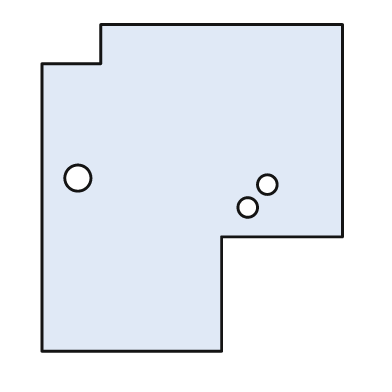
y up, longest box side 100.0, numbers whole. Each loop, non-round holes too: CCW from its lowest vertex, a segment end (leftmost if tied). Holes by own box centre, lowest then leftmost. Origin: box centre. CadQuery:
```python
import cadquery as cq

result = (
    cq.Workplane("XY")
    .moveTo(-46.0, -50.0)
    .lineTo(9.0, -50.0)
    .lineTo(9.0, -15.0)
    .lineTo(46.0, -15.0)
    .lineTo(46.0, 50.0)
    .lineTo(-28.0, 50.0)
    .lineTo(-28.0, 38.0)
    .lineTo(-46.0, 38.0)
    .close()
    .moveTo(17.0, -6.0)
    .circle(3.0)
    .moveTo(23.0, 1.0)
    .circle(3.0)
    .moveTo(-35.0, 3.0)
    .circle(4.0)
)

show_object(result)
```